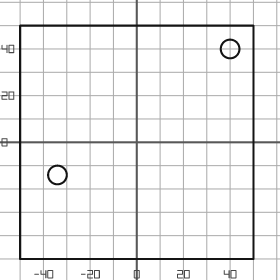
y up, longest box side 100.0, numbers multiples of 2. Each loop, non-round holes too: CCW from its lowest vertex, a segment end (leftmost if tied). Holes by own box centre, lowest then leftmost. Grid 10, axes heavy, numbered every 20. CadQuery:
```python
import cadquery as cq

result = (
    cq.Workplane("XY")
    .moveTo(-50.0, -50.0)
    .lineTo(50.0, -50.0)
    .lineTo(50.0, 50.0)
    .lineTo(-50.0, 50.0)
    .close()
    .moveTo(-34.0, -14.0)
    .circle(4.0)
    .moveTo(40.0, 40.0)
    .circle(4.0)
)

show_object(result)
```